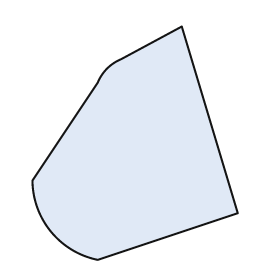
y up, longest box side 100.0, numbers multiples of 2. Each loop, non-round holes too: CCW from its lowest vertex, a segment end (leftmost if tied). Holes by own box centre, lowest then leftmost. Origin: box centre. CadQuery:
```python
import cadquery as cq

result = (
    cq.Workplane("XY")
    .moveTo(-16.0, -50.0)
    .lineTo(44.0, -30.0)
    .lineTo(20.0, 50.0)
    .lineTo(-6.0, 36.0)
    .threePointArc((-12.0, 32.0), (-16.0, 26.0))
    .lineTo(-44.0, -16.0)
    .threePointArc((-36.0, -38.0), (-16.0, -50.0))
    .close()
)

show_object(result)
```